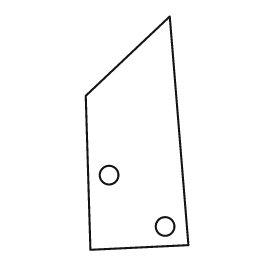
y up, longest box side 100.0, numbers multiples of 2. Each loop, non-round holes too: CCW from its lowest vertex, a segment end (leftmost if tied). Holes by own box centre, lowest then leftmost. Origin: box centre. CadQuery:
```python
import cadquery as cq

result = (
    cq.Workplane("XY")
    .moveTo(-20.0, -50.0)
    .lineTo(22.0, -48.0)
    .lineTo(14.0, 50.0)
    .lineTo(-22.0, 16.0)
    .close()
    .moveTo(12.0, -40.0)
    .circle(4.0)
    .moveTo(-12.0, -18.0)
    .circle(4.0)
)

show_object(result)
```